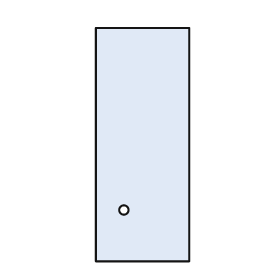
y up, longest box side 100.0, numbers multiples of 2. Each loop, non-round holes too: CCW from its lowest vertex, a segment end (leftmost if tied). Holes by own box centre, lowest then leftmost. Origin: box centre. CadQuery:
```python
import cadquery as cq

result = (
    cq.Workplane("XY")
    .moveTo(-20.0, -50.0)
    .lineTo(20.0, -50.0)
    .lineTo(20.0, 50.0)
    .lineTo(-20.0, 50.0)
    .close()
    .moveTo(-8.0, -28.0)
    .circle(2.0)
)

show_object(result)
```